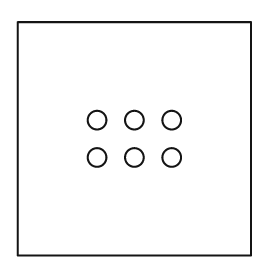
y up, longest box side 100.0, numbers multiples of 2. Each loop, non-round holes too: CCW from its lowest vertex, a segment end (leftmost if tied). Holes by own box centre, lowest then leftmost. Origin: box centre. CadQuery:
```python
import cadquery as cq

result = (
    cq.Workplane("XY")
    .moveTo(-50.0, -50.0)
    .lineTo(50.0, -50.0)
    .lineTo(50.0, 50.0)
    .lineTo(-50.0, 50.0)
    .close()
    .moveTo(-16.0, -8.0)
    .circle(4.0)
    .moveTo(0.0, -8.0)
    .circle(4.0)
    .moveTo(16.0, -8.0)
    .circle(4.0)
    .moveTo(-16.0, 8.0)
    .circle(4.0)
    .moveTo(0.0, 8.0)
    .circle(4.0)
    .moveTo(16.0, 8.0)
    .circle(4.0)
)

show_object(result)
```